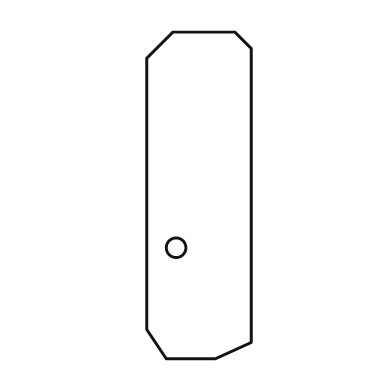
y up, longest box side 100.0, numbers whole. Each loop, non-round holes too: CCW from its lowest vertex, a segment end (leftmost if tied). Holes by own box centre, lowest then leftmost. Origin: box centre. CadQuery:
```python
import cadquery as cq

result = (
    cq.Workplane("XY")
    .moveTo(-10.0, -50.0)
    .lineTo(5.0, -50.0)
    .lineTo(16.0, -45.0)
    .lineTo(16.0, 45.0)
    .lineTo(11.0, 50.0)
    .lineTo(-8.0, 50.0)
    .lineTo(-16.0, 42.0)
    .lineTo(-16.0, -41.0)
    .close()
    .moveTo(-7.0, -16.0)
    .circle(3.0)
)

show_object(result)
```